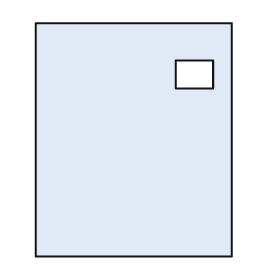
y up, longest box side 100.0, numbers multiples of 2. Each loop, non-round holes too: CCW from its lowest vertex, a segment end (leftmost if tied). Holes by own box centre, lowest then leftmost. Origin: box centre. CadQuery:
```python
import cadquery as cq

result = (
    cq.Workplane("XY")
    .moveTo(-42.0, -50.0)
    .lineTo(42.0, -50.0)
    .lineTo(42.0, 50.0)
    .lineTo(-42.0, 50.0)
    .close()
    .moveTo(18.0, 22.0)
    .lineTo(34.0, 22.0)
    .lineTo(34.0, 34.0)
    .lineTo(18.0, 34.0)
    .close()
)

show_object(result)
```